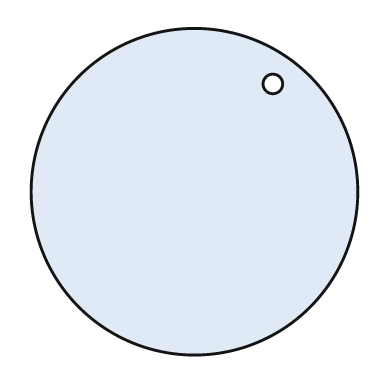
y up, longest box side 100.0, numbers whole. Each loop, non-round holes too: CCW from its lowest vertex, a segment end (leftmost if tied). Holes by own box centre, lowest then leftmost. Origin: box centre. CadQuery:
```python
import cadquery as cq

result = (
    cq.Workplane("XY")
    .moveTo(0.0, 0.0)
    .circle(50.0)
    .moveTo(24.0, 33.0)
    .circle(3.0)
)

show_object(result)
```